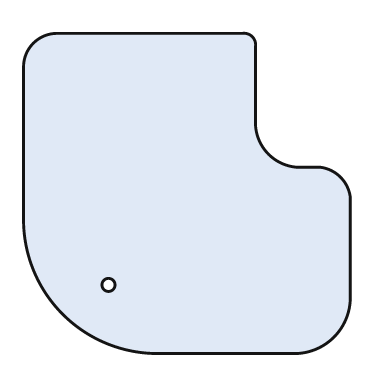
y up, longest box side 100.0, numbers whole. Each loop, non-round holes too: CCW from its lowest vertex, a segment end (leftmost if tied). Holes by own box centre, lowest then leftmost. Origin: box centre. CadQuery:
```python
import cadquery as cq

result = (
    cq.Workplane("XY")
    .moveTo(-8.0, -49.0)
    .lineTo(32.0, -49.0)
    .threePointArc((45.0, -44.0), (50.0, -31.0))
    .lineTo(50.0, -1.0)
    .threePointArc((47.0, 5.0), (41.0, 8.0))
    .lineTo(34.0, 8.0)
    .threePointArc((25.0, 12.0), (21.0, 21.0))
    .lineTo(21.0, 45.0)
    .threePointArc((20.0, 48.0), (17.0, 49.0))
    .lineTo(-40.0, 49.0)
    .threePointArc((-47.0, 46.0), (-50.0, 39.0))
    .lineTo(-50.0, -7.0)
    .threePointArc((-38.0, -37.0), (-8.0, -49.0))
    .close()
    .moveTo(-24.0, -28.0)
    .circle(2.0)
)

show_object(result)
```